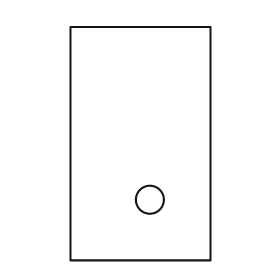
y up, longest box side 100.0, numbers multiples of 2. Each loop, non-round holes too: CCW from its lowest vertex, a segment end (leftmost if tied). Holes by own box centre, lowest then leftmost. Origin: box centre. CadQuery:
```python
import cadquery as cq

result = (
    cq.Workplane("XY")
    .moveTo(-30.0, -50.0)
    .lineTo(30.0, -50.0)
    .lineTo(30.0, 50.0)
    .lineTo(-30.0, 50.0)
    .close()
    .moveTo(4.0, -24.0)
    .circle(6.0)
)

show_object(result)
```